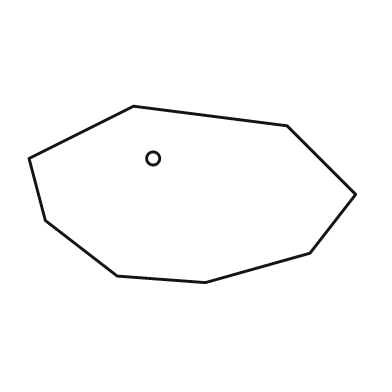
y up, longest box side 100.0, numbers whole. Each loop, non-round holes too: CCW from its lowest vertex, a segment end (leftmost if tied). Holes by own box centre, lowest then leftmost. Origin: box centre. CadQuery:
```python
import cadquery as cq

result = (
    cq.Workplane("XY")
    .moveTo(4.0, -27.0)
    .lineTo(36.0, -18.0)
    .lineTo(50.0, 0.0)
    .lineTo(29.0, 21.0)
    .lineTo(-18.0, 27.0)
    .lineTo(-50.0, 11.0)
    .lineTo(-45.0, -8.0)
    .lineTo(-23.0, -25.0)
    .close()
    .moveTo(-12.0, 11.0)
    .circle(2.0)
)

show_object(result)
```